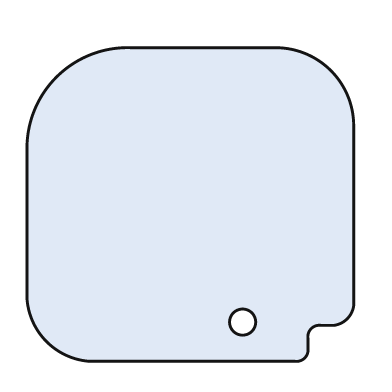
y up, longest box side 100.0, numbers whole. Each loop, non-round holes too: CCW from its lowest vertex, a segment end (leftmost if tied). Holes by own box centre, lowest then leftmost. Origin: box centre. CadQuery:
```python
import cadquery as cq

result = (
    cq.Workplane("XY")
    .moveTo(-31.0, -48.0)
    .lineTo(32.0, -48.0)
    .threePointArc((35.0, -47.0), (36.0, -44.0))
    .lineTo(36.0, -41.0)
    .threePointArc((37.0, -38.0), (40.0, -37.0))
    .lineTo(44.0, -37.0)
    .threePointArc((48.0, -35.0), (50.0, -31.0))
    .lineTo(50.0, 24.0)
    .threePointArc((43.0, 41.0), (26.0, 48.0))
    .lineTo(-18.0, 48.0)
    .threePointArc((-41.0, 39.0), (-50.0, 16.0))
    .lineTo(-50.0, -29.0)
    .threePointArc((-44.0, -42.0), (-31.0, -48.0))
    .close()
    .moveTo(16.0, -36.0)
    .circle(4.0)
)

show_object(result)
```